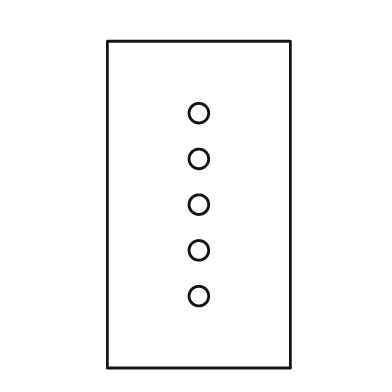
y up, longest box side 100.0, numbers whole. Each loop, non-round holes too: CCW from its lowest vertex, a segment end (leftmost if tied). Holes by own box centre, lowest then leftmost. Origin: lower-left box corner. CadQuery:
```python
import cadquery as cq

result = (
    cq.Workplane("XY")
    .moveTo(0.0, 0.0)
    .lineTo(56.0, 0.0)
    .lineTo(56.0, 100.0)
    .lineTo(0.0, 100.0)
    .close()
    .moveTo(28.0, 22.0)
    .circle(3.0)
    .moveTo(28.0, 36.0)
    .circle(3.0)
    .moveTo(28.0, 50.0)
    .circle(3.0)
    .moveTo(28.0, 64.0)
    .circle(3.0)
    .moveTo(28.0, 78.0)
    .circle(3.0)
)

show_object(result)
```